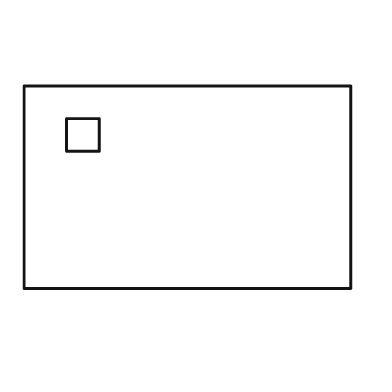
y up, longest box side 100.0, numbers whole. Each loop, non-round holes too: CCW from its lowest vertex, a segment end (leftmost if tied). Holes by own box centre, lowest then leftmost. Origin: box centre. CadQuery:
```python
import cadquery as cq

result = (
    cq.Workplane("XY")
    .moveTo(-50.0, -31.0)
    .lineTo(50.0, -31.0)
    .lineTo(50.0, 31.0)
    .lineTo(-50.0, 31.0)
    .close()
    .moveTo(-37.0, 11.0)
    .lineTo(-27.0, 11.0)
    .lineTo(-27.0, 21.0)
    .lineTo(-37.0, 21.0)
    .close()
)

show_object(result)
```